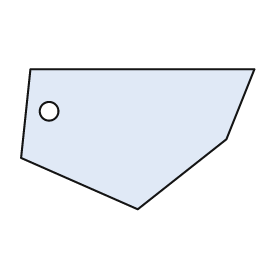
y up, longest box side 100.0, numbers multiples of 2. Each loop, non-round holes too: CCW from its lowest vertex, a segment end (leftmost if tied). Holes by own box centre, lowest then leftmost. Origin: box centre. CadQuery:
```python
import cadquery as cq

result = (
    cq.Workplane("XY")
    .moveTo(0.0, -30.0)
    .lineTo(38.0, 0.0)
    .lineTo(50.0, 30.0)
    .lineTo(-46.0, 30.0)
    .lineTo(-50.0, -8.0)
    .close()
    .moveTo(-38.0, 12.0)
    .circle(4.0)
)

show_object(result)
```